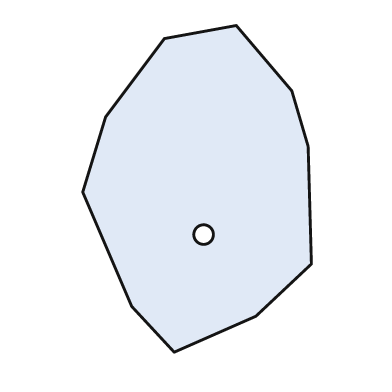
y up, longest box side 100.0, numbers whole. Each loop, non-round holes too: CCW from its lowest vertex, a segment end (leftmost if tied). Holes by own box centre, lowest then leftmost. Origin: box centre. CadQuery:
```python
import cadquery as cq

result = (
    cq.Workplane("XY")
    .moveTo(-7.0, -50.0)
    .lineTo(18.0, -39.0)
    .lineTo(35.0, -23.0)
    .lineTo(34.0, 13.0)
    .lineTo(29.0, 30.0)
    .lineTo(12.0, 50.0)
    .lineTo(-10.0, 46.0)
    .lineTo(-28.0, 22.0)
    .lineTo(-35.0, -1.0)
    .lineTo(-20.0, -36.0)
    .close()
    .moveTo(2.0, -14.0)
    .circle(3.0)
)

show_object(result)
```